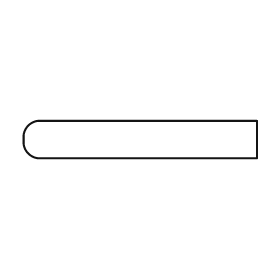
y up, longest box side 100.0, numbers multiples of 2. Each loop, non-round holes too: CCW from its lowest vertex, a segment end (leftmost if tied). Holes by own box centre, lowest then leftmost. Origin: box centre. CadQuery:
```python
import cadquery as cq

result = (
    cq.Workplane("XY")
    .moveTo(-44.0, -8.0)
    .lineTo(50.0, -8.0)
    .lineTo(50.0, 8.0)
    .lineTo(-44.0, 8.0)
    .threePointArc((-48.0, 6.0), (-50.0, 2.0))
    .lineTo(-50.0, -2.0)
    .threePointArc((-48.0, -6.0), (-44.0, -8.0))
    .close()
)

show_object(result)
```